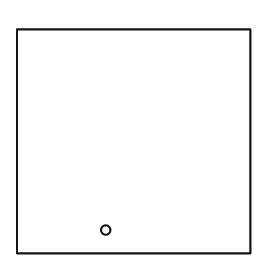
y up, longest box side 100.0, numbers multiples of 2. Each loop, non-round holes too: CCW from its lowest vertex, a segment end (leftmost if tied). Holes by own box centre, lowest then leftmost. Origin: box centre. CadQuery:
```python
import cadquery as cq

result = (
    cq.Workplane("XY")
    .moveTo(-50.0, -48.0)
    .lineTo(50.0, -48.0)
    .lineTo(50.0, 48.0)
    .lineTo(-50.0, 48.0)
    .close()
    .moveTo(-12.0, -38.0)
    .circle(2.0)
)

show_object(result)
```